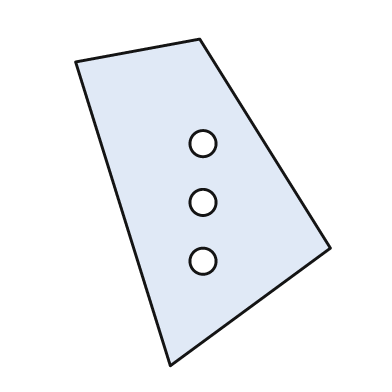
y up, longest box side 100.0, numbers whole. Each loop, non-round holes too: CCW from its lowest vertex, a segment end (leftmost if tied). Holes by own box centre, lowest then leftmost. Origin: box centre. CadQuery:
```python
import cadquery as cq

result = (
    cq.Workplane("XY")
    .moveTo(-10.0, -50.0)
    .lineTo(39.0, -14.0)
    .lineTo(-1.0, 50.0)
    .lineTo(-39.0, 43.0)
    .close()
    .moveTo(0.0, -18.0)
    .circle(4.0)
    .moveTo(0.0, 0.0)
    .circle(4.0)
    .moveTo(0.0, 18.0)
    .circle(4.0)
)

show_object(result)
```